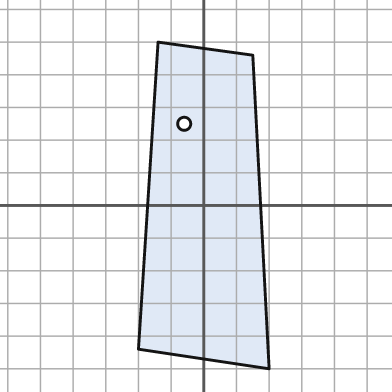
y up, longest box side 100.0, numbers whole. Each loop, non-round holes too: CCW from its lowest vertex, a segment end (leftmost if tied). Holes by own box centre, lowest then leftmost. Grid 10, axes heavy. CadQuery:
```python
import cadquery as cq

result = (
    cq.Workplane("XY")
    .moveTo(20.0, -50.0)
    .lineTo(15.0, 46.0)
    .lineTo(-14.0, 50.0)
    .lineTo(-20.0, -44.0)
    .close()
    .moveTo(-6.0, 25.0)
    .circle(2.0)
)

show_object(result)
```